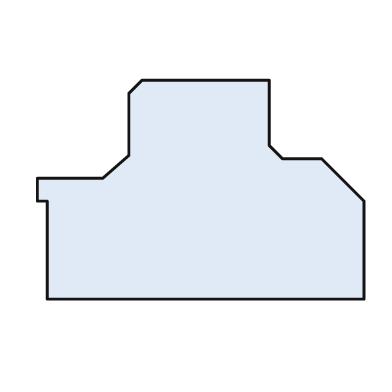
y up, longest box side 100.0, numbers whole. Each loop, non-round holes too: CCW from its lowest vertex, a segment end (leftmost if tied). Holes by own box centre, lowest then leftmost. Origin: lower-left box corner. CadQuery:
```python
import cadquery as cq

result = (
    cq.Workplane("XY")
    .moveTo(3.0, 0.0)
    .lineTo(100.0, 0.0)
    .lineTo(100.0, 30.0)
    .lineTo(87.0, 43.0)
    .lineTo(75.0, 43.0)
    .lineTo(71.0, 47.0)
    .lineTo(71.0, 67.0)
    .lineTo(32.0, 67.0)
    .lineTo(28.0, 63.0)
    .lineTo(28.0, 44.0)
    .lineTo(20.0, 37.0)
    .lineTo(0.0, 37.0)
    .lineTo(0.0, 30.0)
    .lineTo(3.0, 30.0)
    .close()
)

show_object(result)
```